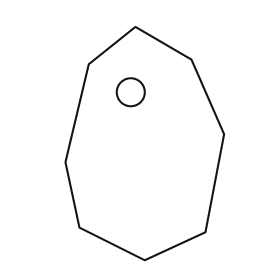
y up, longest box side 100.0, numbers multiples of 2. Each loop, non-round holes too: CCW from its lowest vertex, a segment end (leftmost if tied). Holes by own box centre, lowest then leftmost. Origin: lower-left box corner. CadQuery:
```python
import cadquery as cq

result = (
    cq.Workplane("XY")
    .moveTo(34.0, 0.0)
    .lineTo(60.0, 12.0)
    .lineTo(68.0, 54.0)
    .lineTo(54.0, 86.0)
    .lineTo(30.0, 100.0)
    .lineTo(10.0, 84.0)
    .lineTo(0.0, 42.0)
    .lineTo(6.0, 14.0)
    .close()
    .moveTo(28.0, 72.0)
    .circle(6.0)
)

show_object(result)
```